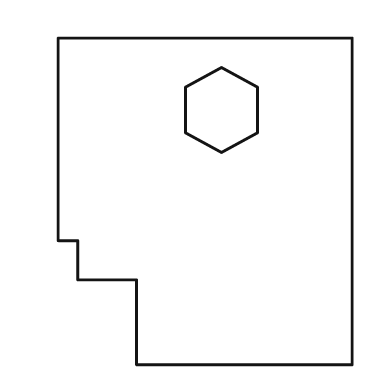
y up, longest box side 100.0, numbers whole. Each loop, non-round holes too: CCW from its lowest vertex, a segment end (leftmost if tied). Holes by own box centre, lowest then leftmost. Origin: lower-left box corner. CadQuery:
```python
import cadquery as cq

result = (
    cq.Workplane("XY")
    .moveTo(24.0, 0.0)
    .lineTo(90.0, 0.0)
    .lineTo(90.0, 100.0)
    .lineTo(0.0, 100.0)
    .lineTo(0.0, 38.0)
    .lineTo(6.0, 38.0)
    .lineTo(6.0, 26.0)
    .lineTo(24.0, 26.0)
    .close()
    .moveTo(50.0, 65.0)
    .lineTo(61.0, 71.0)
    .lineTo(61.0, 85.0)
    .lineTo(50.0, 91.0)
    .lineTo(39.0, 85.0)
    .lineTo(39.0, 71.0)
    .close()
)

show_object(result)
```